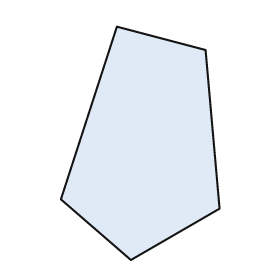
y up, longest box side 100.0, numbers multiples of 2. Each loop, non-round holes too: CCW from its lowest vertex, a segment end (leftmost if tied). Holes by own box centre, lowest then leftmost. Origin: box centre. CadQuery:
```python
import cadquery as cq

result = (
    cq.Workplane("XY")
    .moveTo(-4.0, -50.0)
    .lineTo(34.0, -28.0)
    .lineTo(28.0, 40.0)
    .lineTo(-10.0, 50.0)
    .lineTo(-34.0, -24.0)
    .close()
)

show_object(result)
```